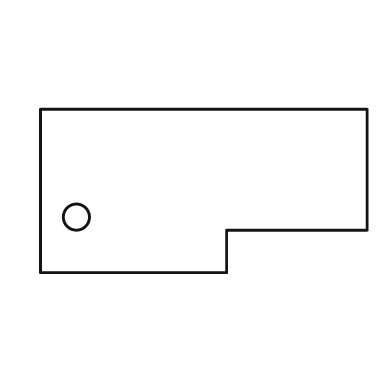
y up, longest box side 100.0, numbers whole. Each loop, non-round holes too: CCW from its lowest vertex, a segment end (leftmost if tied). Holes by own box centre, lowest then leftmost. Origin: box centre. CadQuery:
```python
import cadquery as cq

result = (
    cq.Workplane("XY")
    .moveTo(-50.0, -25.0)
    .lineTo(7.0, -25.0)
    .lineTo(7.0, -12.0)
    .lineTo(50.0, -12.0)
    .lineTo(50.0, 25.0)
    .lineTo(-50.0, 25.0)
    .close()
    .moveTo(-39.0, -8.0)
    .circle(4.0)
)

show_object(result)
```